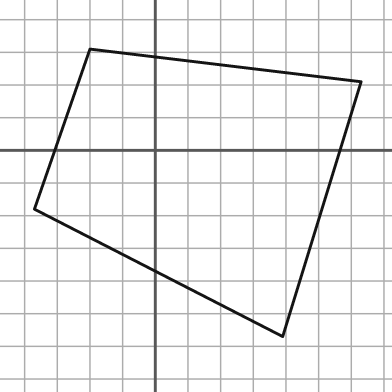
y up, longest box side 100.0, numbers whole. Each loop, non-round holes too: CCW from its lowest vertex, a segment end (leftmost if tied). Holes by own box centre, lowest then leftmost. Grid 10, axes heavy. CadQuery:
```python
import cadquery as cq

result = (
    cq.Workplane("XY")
    .moveTo(39.0, -57.0)
    .lineTo(63.0, 21.0)
    .lineTo(-20.0, 31.0)
    .lineTo(-37.0, -18.0)
    .close()
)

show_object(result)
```